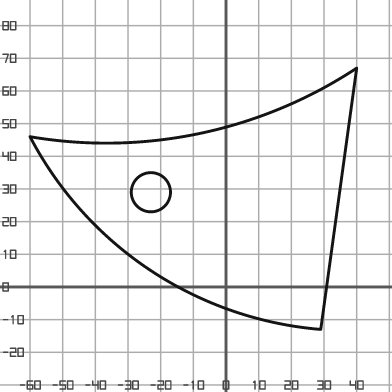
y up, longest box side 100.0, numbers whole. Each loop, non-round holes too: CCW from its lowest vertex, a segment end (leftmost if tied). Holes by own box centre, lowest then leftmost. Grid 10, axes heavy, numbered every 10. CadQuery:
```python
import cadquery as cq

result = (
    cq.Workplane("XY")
    .moveTo(29.0, -13.0)
    .lineTo(40.0, 67.0)
    .threePointArc((-8.0, 47.0), (-60.0, 46.0))
    .threePointArc((-23.0, 5.0), (29.0, -13.0))
    .close()
    .moveTo(-23.0, 29.0)
    .circle(6.0)
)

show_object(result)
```